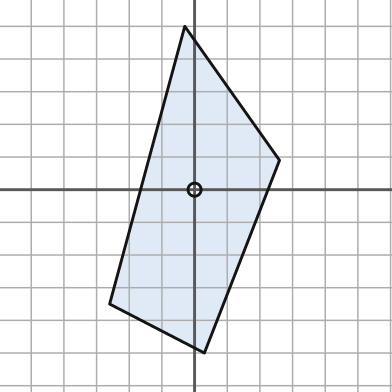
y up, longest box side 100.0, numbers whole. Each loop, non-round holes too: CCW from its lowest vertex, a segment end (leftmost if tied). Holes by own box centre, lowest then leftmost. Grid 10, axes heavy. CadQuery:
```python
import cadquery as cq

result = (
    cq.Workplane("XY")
    .moveTo(3.0, -50.0)
    .lineTo(26.0, 9.0)
    .lineTo(-3.0, 50.0)
    .lineTo(-26.0, -35.0)
    .close()
    .moveTo(0.0, 0.0)
    .circle(2.0)
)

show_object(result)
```